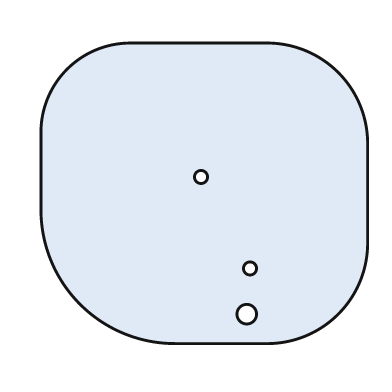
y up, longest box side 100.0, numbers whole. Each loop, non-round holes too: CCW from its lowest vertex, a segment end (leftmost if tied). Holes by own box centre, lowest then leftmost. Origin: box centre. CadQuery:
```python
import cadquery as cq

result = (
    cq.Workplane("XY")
    .moveTo(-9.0, -46.0)
    .lineTo(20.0, -46.0)
    .threePointArc((41.0, -37.0), (50.0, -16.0))
    .lineTo(50.0, 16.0)
    .threePointArc((41.0, 37.0), (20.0, 46.0))
    .lineTo(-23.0, 46.0)
    .threePointArc((-42.0, 38.0), (-50.0, 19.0))
    .lineTo(-50.0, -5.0)
    .threePointArc((-38.0, -34.0), (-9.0, -46.0))
    .close()
    .moveTo(13.0, -37.0)
    .circle(3.0)
    .moveTo(14.0, -23.0)
    .circle(2.0)
    .moveTo(-1.0, 5.0)
    .circle(2.0)
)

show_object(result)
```